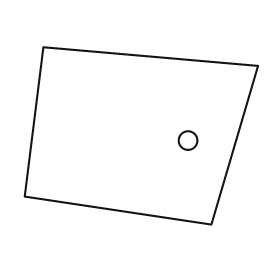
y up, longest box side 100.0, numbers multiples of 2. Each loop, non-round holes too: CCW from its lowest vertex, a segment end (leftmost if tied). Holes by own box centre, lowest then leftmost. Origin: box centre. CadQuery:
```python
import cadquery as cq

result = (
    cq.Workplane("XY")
    .moveTo(30.0, -38.0)
    .lineTo(50.0, 30.0)
    .lineTo(-42.0, 38.0)
    .lineTo(-50.0, -26.0)
    .close()
    .moveTo(20.0, -2.0)
    .circle(4.0)
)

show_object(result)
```